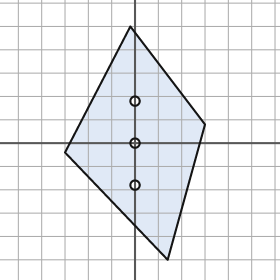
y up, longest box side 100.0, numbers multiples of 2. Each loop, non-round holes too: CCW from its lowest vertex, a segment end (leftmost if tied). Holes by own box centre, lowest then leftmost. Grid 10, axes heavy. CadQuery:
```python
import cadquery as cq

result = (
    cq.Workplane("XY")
    .moveTo(14.0, -50.0)
    .lineTo(30.0, 8.0)
    .lineTo(-2.0, 50.0)
    .lineTo(-30.0, -4.0)
    .close()
    .moveTo(0.0, -18.0)
    .circle(2.0)
    .moveTo(0.0, 0.0)
    .circle(2.0)
    .moveTo(0.0, 18.0)
    .circle(2.0)
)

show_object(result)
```